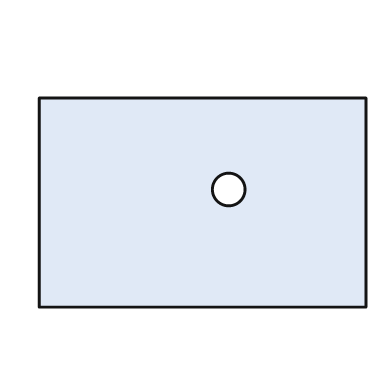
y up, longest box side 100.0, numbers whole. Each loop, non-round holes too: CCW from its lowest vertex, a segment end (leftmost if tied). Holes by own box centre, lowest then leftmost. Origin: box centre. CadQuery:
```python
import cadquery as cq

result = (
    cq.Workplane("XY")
    .moveTo(-50.0, -32.0)
    .lineTo(50.0, -32.0)
    .lineTo(50.0, 32.0)
    .lineTo(-50.0, 32.0)
    .close()
    .moveTo(8.0, 4.0)
    .circle(5.0)
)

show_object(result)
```